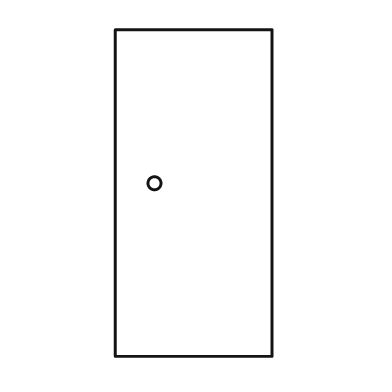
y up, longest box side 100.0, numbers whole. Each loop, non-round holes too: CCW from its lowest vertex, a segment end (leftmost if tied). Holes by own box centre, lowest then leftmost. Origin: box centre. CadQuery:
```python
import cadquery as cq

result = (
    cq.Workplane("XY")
    .moveTo(-24.0, -50.0)
    .lineTo(24.0, -50.0)
    .lineTo(24.0, 50.0)
    .lineTo(-24.0, 50.0)
    .close()
    .moveTo(-12.0, 3.0)
    .circle(2.0)
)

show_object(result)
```